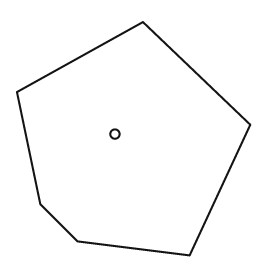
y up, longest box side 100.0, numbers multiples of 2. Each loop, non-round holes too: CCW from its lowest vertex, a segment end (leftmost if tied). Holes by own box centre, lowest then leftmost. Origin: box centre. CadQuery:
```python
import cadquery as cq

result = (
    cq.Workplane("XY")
    .moveTo(24.0, -50.0)
    .lineTo(50.0, 6.0)
    .lineTo(4.0, 50.0)
    .lineTo(-50.0, 20.0)
    .lineTo(-40.0, -28.0)
    .lineTo(-24.0, -44.0)
    .close()
    .moveTo(-8.0, 2.0)
    .circle(2.0)
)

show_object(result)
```